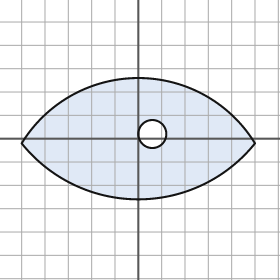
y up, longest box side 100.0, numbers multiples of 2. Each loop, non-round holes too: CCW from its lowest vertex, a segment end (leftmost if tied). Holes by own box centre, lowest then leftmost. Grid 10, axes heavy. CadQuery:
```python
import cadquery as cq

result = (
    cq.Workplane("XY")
    .moveTo(-50.0, -2.0)
    .threePointArc((0.0, -26.0), (50.0, -2.0))
    .threePointArc((0.0, 26.0), (-50.0, -2.0))
    .close()
    .moveTo(6.0, 2.0)
    .circle(6.0)
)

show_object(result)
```